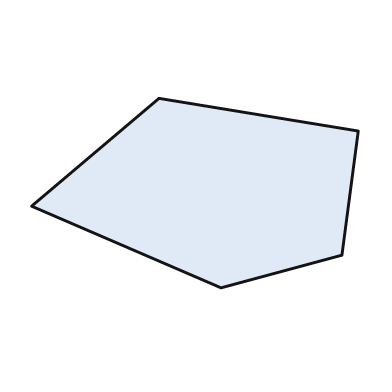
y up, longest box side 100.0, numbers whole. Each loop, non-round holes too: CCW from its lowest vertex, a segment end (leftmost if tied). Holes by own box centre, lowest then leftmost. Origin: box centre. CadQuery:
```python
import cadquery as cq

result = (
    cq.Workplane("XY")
    .moveTo(8.0, -29.0)
    .lineTo(45.0, -19.0)
    .lineTo(50.0, 19.0)
    .lineTo(-11.0, 29.0)
    .lineTo(-50.0, -4.0)
    .close()
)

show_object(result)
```